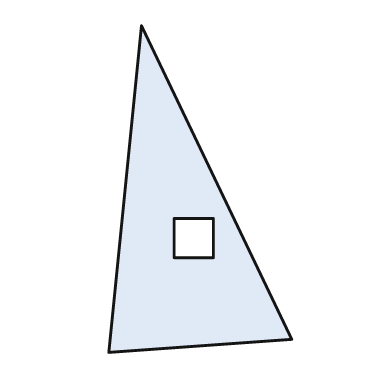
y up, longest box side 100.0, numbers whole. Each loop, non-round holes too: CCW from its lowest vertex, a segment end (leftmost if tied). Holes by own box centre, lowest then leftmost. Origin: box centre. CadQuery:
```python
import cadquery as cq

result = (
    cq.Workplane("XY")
    .moveTo(-28.0, -50.0)
    .lineTo(28.0, -46.0)
    .lineTo(-18.0, 50.0)
    .close()
    .moveTo(-8.0, -21.0)
    .lineTo(4.0, -21.0)
    .lineTo(4.0, -9.0)
    .lineTo(-8.0, -9.0)
    .close()
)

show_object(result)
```